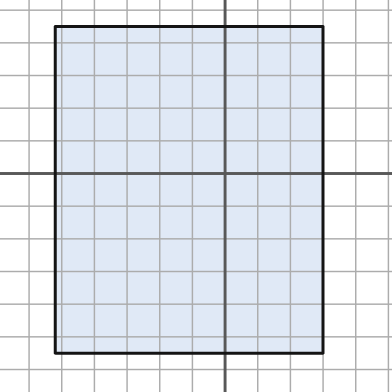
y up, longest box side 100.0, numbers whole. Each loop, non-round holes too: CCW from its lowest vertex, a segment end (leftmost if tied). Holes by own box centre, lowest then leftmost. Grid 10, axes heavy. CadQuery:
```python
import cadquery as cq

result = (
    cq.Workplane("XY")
    .moveTo(-52.0, -55.0)
    .lineTo(30.0, -55.0)
    .lineTo(30.0, 45.0)
    .lineTo(-52.0, 45.0)
    .close()
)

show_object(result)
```